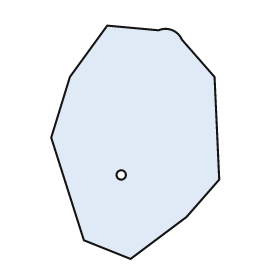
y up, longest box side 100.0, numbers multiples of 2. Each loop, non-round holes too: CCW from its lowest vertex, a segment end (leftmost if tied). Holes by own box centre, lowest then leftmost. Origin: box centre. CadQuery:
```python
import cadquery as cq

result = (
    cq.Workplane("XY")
    .moveTo(-2.0, -50.0)
    .lineTo(22.0, -32.0)
    .lineTo(36.0, -16.0)
    .lineTo(34.0, 28.0)
    .lineTo(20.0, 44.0)
    .threePointArc((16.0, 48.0), (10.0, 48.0))
    .lineTo(-12.0, 50.0)
    .lineTo(-28.0, 28.0)
    .lineTo(-36.0, 2.0)
    .lineTo(-22.0, -42.0)
    .close()
    .moveTo(-6.0, -14.0)
    .circle(2.0)
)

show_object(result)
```